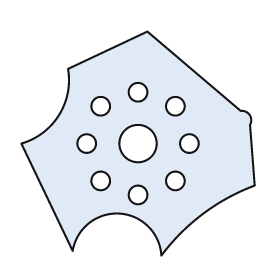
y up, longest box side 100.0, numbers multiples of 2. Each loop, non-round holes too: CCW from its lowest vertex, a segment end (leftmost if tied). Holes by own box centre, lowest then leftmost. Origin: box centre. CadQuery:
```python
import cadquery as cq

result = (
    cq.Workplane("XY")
    .moveTo(10.0, -48.0)
    .threePointArc((28.0, -30.0), (50.0, -18.0))
    .lineTo(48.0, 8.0)
    .threePointArc((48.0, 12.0), (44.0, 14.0))
    .lineTo(4.0, 48.0)
    .lineTo(-30.0, 32.0)
    .threePointArc((-34.0, 12.0), (-50.0, 0.0))
    .lineTo(-28.0, -46.0)
    .threePointArc((-8.0, -30.0), (10.0, -48.0))
    .close()
    .moveTo(0.0, -22.0)
    .circle(4.0)
    .moveTo(-16.0, -16.0)
    .circle(4.0)
    .moveTo(16.0, -16.0)
    .circle(4.0)
    .moveTo(-22.0, 0.0)
    .circle(4.0)
    .moveTo(0.0, 0.0)
    .circle(8.0)
    .moveTo(22.0, 0.0)
    .circle(4.0)
    .moveTo(-16.0, 16.0)
    .circle(4.0)
    .moveTo(16.0, 16.0)
    .circle(4.0)
    .moveTo(0.0, 22.0)
    .circle(4.0)
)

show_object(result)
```